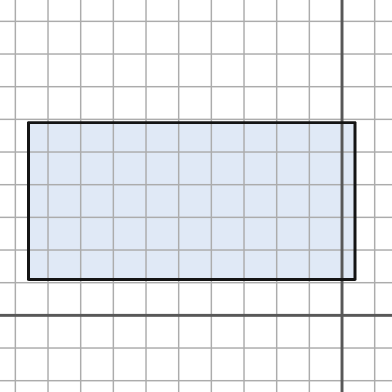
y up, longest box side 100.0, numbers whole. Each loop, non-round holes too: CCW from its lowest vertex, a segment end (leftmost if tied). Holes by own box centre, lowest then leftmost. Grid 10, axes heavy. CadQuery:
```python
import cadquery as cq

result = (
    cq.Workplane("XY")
    .moveTo(-96.0, 11.0)
    .lineTo(4.0, 11.0)
    .lineTo(4.0, 59.0)
    .lineTo(-96.0, 59.0)
    .close()
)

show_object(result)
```